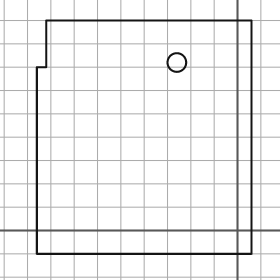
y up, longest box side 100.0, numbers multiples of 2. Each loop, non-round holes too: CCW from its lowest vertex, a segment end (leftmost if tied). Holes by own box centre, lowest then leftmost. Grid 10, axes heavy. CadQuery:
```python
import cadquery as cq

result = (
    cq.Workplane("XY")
    .moveTo(-86.0, -10.0)
    .lineTo(6.0, -10.0)
    .lineTo(6.0, 90.0)
    .lineTo(-82.0, 90.0)
    .lineTo(-82.0, 70.0)
    .lineTo(-86.0, 70.0)
    .close()
    .moveTo(-26.0, 72.0)
    .circle(4.0)
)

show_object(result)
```